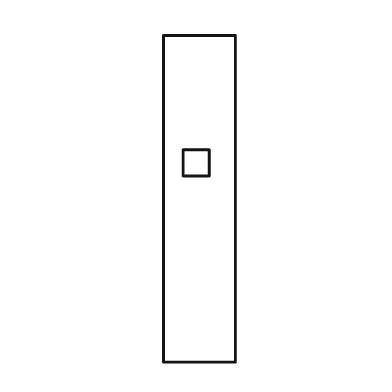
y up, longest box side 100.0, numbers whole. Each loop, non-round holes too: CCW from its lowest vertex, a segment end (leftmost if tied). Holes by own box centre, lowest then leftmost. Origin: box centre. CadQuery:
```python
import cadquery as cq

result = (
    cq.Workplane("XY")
    .moveTo(-11.0, -50.0)
    .lineTo(11.0, -50.0)
    .lineTo(11.0, 50.0)
    .lineTo(-11.0, 50.0)
    .close()
    .moveTo(-5.0, 7.0)
    .lineTo(3.0, 7.0)
    .lineTo(3.0, 15.0)
    .lineTo(-5.0, 15.0)
    .close()
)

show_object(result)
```